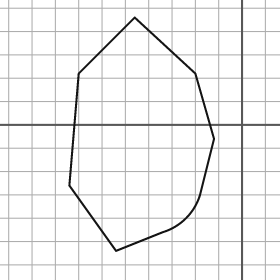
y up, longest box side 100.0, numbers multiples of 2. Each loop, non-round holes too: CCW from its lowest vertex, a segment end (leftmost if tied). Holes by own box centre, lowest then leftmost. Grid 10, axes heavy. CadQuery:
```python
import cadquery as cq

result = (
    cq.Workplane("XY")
    .moveTo(-54.0, -54.0)
    .lineTo(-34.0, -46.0)
    .threePointArc((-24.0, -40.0), (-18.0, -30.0))
    .lineTo(-12.0, -6.0)
    .lineTo(-20.0, 22.0)
    .lineTo(-46.0, 46.0)
    .lineTo(-70.0, 22.0)
    .lineTo(-74.0, -26.0)
    .close()
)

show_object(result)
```